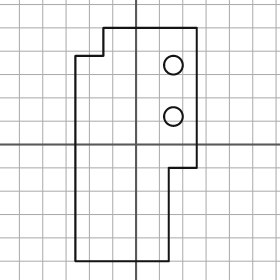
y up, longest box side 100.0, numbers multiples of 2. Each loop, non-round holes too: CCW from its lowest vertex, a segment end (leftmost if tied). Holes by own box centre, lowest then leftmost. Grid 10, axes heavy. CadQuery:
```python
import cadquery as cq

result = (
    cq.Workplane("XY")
    .moveTo(-26.0, -50.0)
    .lineTo(14.0, -50.0)
    .lineTo(14.0, -10.0)
    .lineTo(26.0, -10.0)
    .lineTo(26.0, 50.0)
    .lineTo(-14.0, 50.0)
    .lineTo(-14.0, 38.0)
    .lineTo(-26.0, 38.0)
    .close()
    .moveTo(16.0, 12.0)
    .circle(4.0)
    .moveTo(16.0, 34.0)
    .circle(4.0)
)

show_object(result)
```